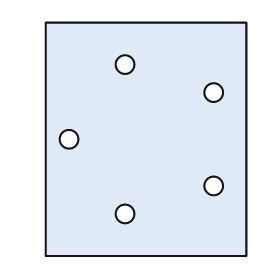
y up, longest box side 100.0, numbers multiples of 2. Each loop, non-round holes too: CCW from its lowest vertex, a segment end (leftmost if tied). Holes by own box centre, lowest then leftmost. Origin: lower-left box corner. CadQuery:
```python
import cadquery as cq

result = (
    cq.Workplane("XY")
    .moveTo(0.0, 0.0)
    .lineTo(86.0, 0.0)
    .lineTo(86.0, 100.0)
    .lineTo(0.0, 100.0)
    .close()
    .moveTo(34.0, 18.0)
    .circle(4.0)
    .moveTo(72.0, 30.0)
    .circle(4.0)
    .moveTo(10.0, 50.0)
    .circle(4.0)
    .moveTo(72.0, 70.0)
    .circle(4.0)
    .moveTo(34.0, 82.0)
    .circle(4.0)
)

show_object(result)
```